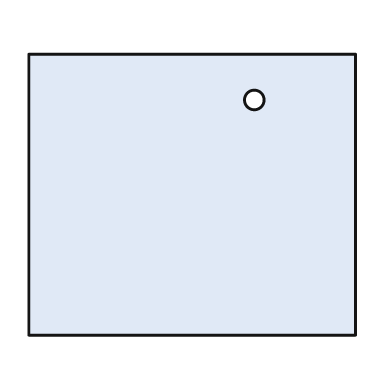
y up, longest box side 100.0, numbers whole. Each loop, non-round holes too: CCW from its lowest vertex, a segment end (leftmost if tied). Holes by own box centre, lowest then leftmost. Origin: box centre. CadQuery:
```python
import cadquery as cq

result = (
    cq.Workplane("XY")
    .moveTo(-50.0, -43.0)
    .lineTo(50.0, -43.0)
    .lineTo(50.0, 43.0)
    .lineTo(-50.0, 43.0)
    .close()
    .moveTo(19.0, 29.0)
    .circle(3.0)
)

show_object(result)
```